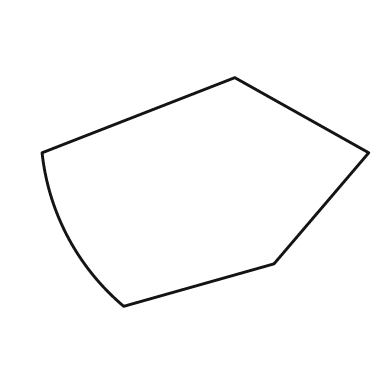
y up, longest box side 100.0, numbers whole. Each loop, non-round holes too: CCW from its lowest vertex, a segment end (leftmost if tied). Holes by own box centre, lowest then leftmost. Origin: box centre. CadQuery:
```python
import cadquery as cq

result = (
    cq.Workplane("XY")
    .moveTo(-25.0, -35.0)
    .lineTo(21.0, -22.0)
    .lineTo(50.0, 12.0)
    .lineTo(9.0, 35.0)
    .lineTo(-50.0, 12.0)
    .threePointArc((-42.0, -14.0), (-25.0, -35.0))
    .close()
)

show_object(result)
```